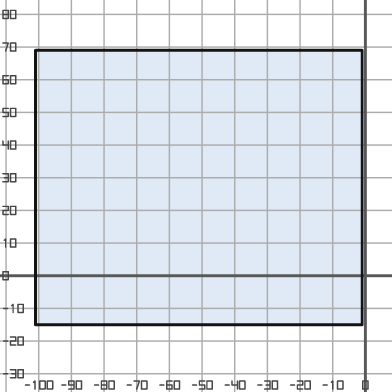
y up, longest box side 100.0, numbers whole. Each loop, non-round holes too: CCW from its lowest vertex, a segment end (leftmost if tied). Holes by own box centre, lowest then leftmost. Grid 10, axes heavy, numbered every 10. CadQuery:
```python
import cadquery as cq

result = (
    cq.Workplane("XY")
    .moveTo(-101.0, -15.0)
    .lineTo(-1.0, -15.0)
    .lineTo(-1.0, 69.0)
    .lineTo(-101.0, 69.0)
    .close()
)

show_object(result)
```